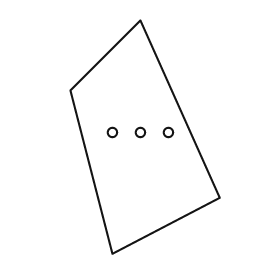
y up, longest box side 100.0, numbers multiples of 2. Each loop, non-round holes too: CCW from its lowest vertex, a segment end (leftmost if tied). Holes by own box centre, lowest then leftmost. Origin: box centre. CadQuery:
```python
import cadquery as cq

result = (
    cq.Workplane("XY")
    .moveTo(-14.0, -50.0)
    .lineTo(32.0, -26.0)
    .lineTo(-2.0, 50.0)
    .lineTo(-32.0, 20.0)
    .close()
    .moveTo(-14.0, 2.0)
    .circle(2.0)
    .moveTo(-2.0, 2.0)
    .circle(2.0)
    .moveTo(10.0, 2.0)
    .circle(2.0)
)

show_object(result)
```